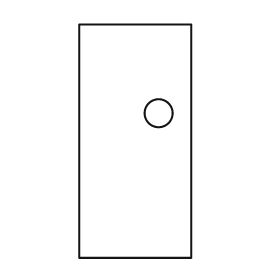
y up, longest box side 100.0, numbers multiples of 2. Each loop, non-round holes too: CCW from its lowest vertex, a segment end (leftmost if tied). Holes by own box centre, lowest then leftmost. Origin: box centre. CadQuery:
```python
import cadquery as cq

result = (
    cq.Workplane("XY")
    .moveTo(-24.0, -50.0)
    .lineTo(24.0, -50.0)
    .lineTo(24.0, 50.0)
    .lineTo(-24.0, 50.0)
    .close()
    .moveTo(10.0, 12.0)
    .circle(6.0)
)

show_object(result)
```